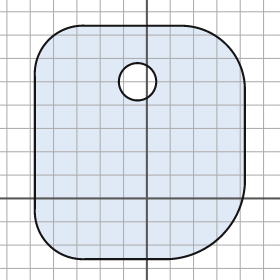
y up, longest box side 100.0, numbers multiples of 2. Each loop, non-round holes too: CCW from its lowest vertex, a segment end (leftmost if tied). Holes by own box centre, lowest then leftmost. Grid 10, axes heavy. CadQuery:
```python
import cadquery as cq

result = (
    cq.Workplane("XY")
    .moveTo(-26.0, -26.0)
    .lineTo(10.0, -26.0)
    .threePointArc((32.0, -16.0), (42.0, 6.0))
    .lineTo(42.0, 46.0)
    .threePointArc((34.0, 66.0), (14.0, 74.0))
    .lineTo(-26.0, 74.0)
    .threePointArc((-42.0, 68.0), (-48.0, 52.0))
    .lineTo(-48.0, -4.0)
    .threePointArc((-42.0, -20.0), (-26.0, -26.0))
    .close()
    .moveTo(-4.0, 50.0)
    .circle(8.0)
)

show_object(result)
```